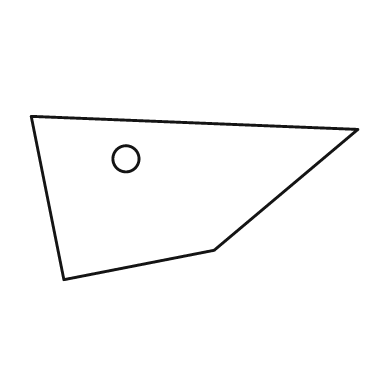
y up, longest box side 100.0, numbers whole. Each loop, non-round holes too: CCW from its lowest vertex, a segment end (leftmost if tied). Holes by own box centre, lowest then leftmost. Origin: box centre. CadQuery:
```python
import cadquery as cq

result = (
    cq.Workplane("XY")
    .moveTo(-40.0, -25.0)
    .lineTo(6.0, -16.0)
    .lineTo(50.0, 21.0)
    .lineTo(-50.0, 25.0)
    .close()
    .moveTo(-21.0, 12.0)
    .circle(4.0)
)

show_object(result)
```